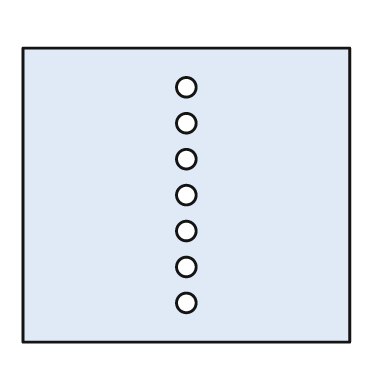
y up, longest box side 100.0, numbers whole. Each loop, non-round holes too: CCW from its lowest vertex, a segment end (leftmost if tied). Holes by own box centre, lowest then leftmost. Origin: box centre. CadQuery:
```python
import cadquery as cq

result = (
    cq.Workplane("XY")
    .moveTo(-50.0, -45.0)
    .lineTo(50.0, -45.0)
    .lineTo(50.0, 45.0)
    .lineTo(-50.0, 45.0)
    .close()
    .moveTo(0.0, -33.0)
    .circle(3.0)
    .moveTo(0.0, -22.0)
    .circle(3.0)
    .moveTo(0.0, -11.0)
    .circle(3.0)
    .moveTo(0.0, 0.0)
    .circle(3.0)
    .moveTo(0.0, 11.0)
    .circle(3.0)
    .moveTo(0.0, 22.0)
    .circle(3.0)
    .moveTo(0.0, 33.0)
    .circle(3.0)
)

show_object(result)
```